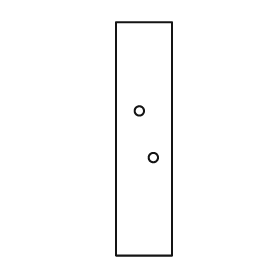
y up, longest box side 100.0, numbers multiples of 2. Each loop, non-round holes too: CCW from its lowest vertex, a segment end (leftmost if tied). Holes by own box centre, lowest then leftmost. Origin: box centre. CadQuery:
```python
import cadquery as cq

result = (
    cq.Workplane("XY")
    .moveTo(-12.0, -50.0)
    .lineTo(12.0, -50.0)
    .lineTo(12.0, 50.0)
    .lineTo(-12.0, 50.0)
    .close()
    .moveTo(4.0, -8.0)
    .circle(2.0)
    .moveTo(-2.0, 12.0)
    .circle(2.0)
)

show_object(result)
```